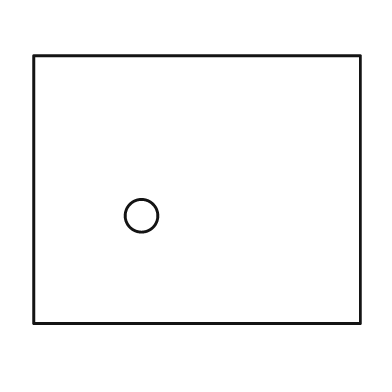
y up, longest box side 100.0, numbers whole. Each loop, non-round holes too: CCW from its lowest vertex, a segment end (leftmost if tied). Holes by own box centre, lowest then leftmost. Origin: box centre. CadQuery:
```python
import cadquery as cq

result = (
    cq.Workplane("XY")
    .moveTo(-50.0, -41.0)
    .lineTo(50.0, -41.0)
    .lineTo(50.0, 41.0)
    .lineTo(-50.0, 41.0)
    .close()
    .moveTo(-17.0, -8.0)
    .circle(5.0)
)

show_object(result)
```